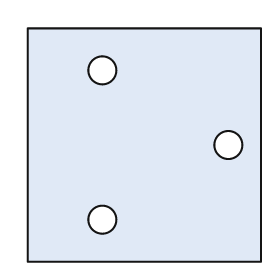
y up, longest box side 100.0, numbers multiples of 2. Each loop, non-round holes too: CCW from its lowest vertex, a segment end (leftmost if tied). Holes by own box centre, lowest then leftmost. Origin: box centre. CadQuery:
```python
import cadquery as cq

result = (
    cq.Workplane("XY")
    .moveTo(-50.0, -50.0)
    .lineTo(50.0, -50.0)
    .lineTo(50.0, 50.0)
    .lineTo(-50.0, 50.0)
    .close()
    .moveTo(-18.0, -32.0)
    .circle(6.0)
    .moveTo(36.0, 0.0)
    .circle(6.0)
    .moveTo(-18.0, 32.0)
    .circle(6.0)
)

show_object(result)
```